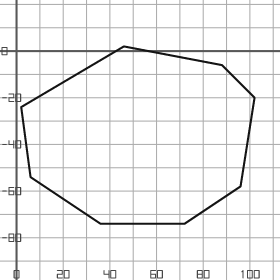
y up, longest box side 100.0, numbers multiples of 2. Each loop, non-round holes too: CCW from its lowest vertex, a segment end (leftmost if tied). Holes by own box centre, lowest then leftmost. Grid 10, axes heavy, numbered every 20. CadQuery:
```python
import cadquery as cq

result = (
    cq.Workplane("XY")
    .moveTo(36.0, -74.0)
    .lineTo(72.0, -74.0)
    .lineTo(96.0, -58.0)
    .lineTo(102.0, -20.0)
    .lineTo(88.0, -6.0)
    .lineTo(46.0, 2.0)
    .lineTo(2.0, -24.0)
    .lineTo(6.0, -54.0)
    .close()
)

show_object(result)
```